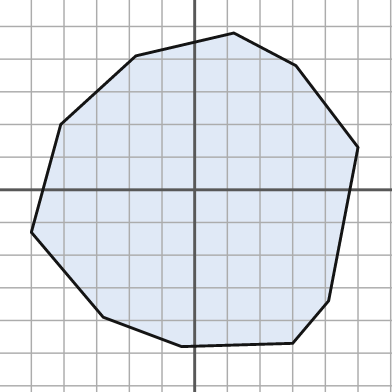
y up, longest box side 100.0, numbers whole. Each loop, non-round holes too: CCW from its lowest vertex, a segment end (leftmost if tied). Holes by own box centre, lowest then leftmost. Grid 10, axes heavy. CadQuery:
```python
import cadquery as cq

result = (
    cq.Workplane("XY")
    .moveTo(-4.0, -48.0)
    .lineTo(30.0, -47.0)
    .lineTo(41.0, -34.0)
    .lineTo(50.0, 13.0)
    .lineTo(31.0, 38.0)
    .lineTo(12.0, 48.0)
    .lineTo(-18.0, 41.0)
    .lineTo(-41.0, 20.0)
    .lineTo(-50.0, -13.0)
    .lineTo(-28.0, -39.0)
    .close()
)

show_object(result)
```